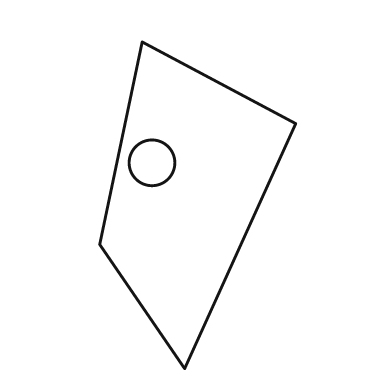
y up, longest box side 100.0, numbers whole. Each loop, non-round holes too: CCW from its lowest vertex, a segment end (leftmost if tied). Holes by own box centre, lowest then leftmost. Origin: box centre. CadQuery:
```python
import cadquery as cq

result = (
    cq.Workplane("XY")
    .moveTo(-4.0, -50.0)
    .lineTo(30.0, 25.0)
    .lineTo(-17.0, 50.0)
    .lineTo(-30.0, -12.0)
    .close()
    .moveTo(-14.0, 13.0)
    .circle(7.0)
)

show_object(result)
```